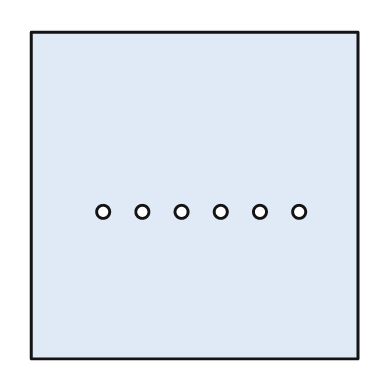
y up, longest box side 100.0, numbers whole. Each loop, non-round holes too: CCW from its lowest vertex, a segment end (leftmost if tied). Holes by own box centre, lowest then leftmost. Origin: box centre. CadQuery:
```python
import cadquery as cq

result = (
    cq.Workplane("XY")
    .moveTo(-50.0, -50.0)
    .lineTo(50.0, -50.0)
    .lineTo(50.0, 50.0)
    .lineTo(-50.0, 50.0)
    .close()
    .moveTo(-28.0, -5.0)
    .circle(2.0)
    .moveTo(-16.0, -5.0)
    .circle(2.0)
    .moveTo(-4.0, -5.0)
    .circle(2.0)
    .moveTo(8.0, -5.0)
    .circle(2.0)
    .moveTo(20.0, -5.0)
    .circle(2.0)
    .moveTo(32.0, -5.0)
    .circle(2.0)
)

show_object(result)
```